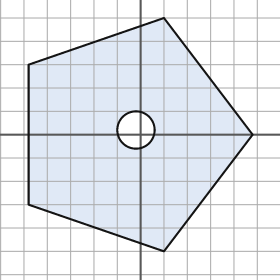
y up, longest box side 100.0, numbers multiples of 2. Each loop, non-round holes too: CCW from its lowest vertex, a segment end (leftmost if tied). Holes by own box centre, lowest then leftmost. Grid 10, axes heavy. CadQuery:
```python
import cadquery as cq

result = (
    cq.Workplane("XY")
    .moveTo(10.0, -50.0)
    .lineTo(48.0, 0.0)
    .lineTo(10.0, 50.0)
    .lineTo(-48.0, 30.0)
    .lineTo(-48.0, -30.0)
    .close()
    .moveTo(-2.0, 2.0)
    .circle(8.0)
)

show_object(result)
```